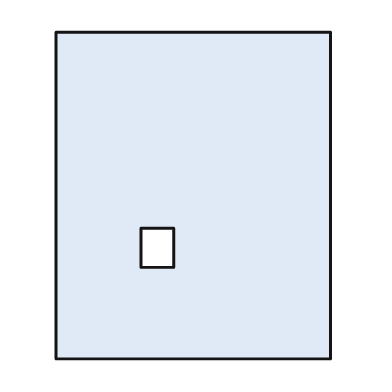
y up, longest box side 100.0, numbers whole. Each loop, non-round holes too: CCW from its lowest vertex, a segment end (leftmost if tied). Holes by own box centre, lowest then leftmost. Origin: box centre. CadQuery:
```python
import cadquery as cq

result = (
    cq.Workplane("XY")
    .moveTo(-42.0, -50.0)
    .lineTo(42.0, -50.0)
    .lineTo(42.0, 50.0)
    .lineTo(-42.0, 50.0)
    .close()
    .moveTo(-16.0, -22.0)
    .lineTo(-6.0, -22.0)
    .lineTo(-6.0, -10.0)
    .lineTo(-16.0, -10.0)
    .close()
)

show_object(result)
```